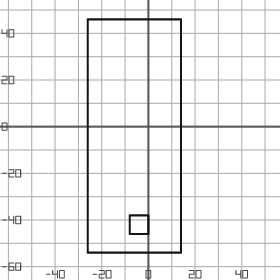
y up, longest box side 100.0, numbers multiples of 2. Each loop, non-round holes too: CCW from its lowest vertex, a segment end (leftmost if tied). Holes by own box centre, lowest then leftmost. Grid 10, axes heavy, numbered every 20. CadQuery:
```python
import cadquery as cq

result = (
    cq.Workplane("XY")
    .moveTo(-26.0, -54.0)
    .lineTo(14.0, -54.0)
    .lineTo(14.0, 46.0)
    .lineTo(-26.0, 46.0)
    .close()
    .moveTo(-8.0, -46.0)
    .lineTo(0.0, -46.0)
    .lineTo(0.0, -38.0)
    .lineTo(-8.0, -38.0)
    .close()
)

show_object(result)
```